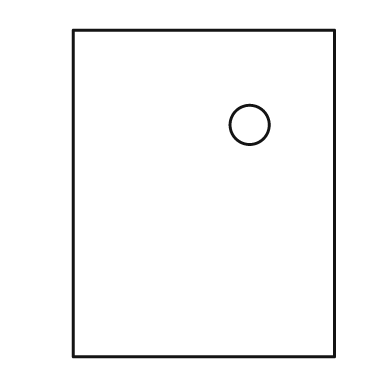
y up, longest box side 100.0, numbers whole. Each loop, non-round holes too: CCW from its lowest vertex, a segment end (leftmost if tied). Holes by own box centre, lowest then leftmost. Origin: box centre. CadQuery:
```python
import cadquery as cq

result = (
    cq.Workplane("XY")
    .moveTo(-40.0, -50.0)
    .lineTo(40.0, -50.0)
    .lineTo(40.0, 50.0)
    .lineTo(-40.0, 50.0)
    .close()
    .moveTo(14.0, 21.0)
    .circle(6.0)
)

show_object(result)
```